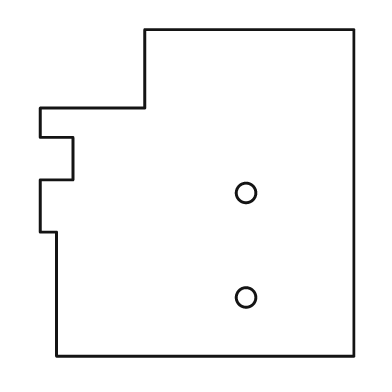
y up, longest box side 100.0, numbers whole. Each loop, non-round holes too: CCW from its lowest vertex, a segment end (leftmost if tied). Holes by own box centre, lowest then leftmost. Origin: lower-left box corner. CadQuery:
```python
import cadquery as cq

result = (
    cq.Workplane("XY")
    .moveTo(5.0, 0.0)
    .lineTo(96.0, 0.0)
    .lineTo(96.0, 100.0)
    .lineTo(32.0, 100.0)
    .lineTo(32.0, 76.0)
    .lineTo(0.0, 76.0)
    .lineTo(0.0, 67.0)
    .lineTo(10.0, 67.0)
    .lineTo(10.0, 54.0)
    .lineTo(0.0, 54.0)
    .lineTo(0.0, 38.0)
    .lineTo(5.0, 38.0)
    .close()
    .moveTo(63.0, 18.0)
    .circle(3.0)
    .moveTo(63.0, 50.0)
    .circle(3.0)
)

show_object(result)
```